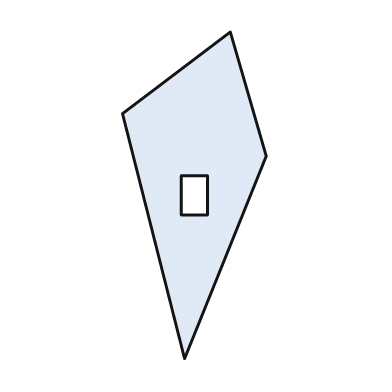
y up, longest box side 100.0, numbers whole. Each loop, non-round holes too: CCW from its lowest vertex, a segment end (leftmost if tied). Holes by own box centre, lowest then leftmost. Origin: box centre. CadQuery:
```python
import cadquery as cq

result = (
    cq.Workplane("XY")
    .moveTo(-3.0, -50.0)
    .lineTo(22.0, 12.0)
    .lineTo(11.0, 50.0)
    .lineTo(-22.0, 25.0)
    .close()
    .moveTo(-4.0, -6.0)
    .lineTo(4.0, -6.0)
    .lineTo(4.0, 6.0)
    .lineTo(-4.0, 6.0)
    .close()
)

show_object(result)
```